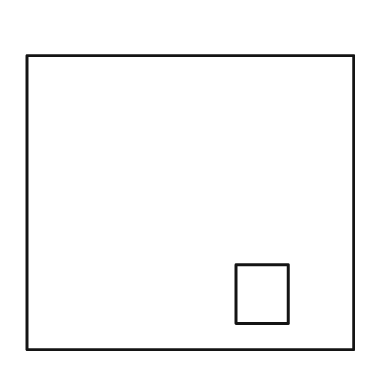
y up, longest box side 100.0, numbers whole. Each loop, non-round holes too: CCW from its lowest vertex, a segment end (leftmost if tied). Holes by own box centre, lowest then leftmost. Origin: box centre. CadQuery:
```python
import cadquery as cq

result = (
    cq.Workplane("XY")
    .moveTo(-50.0, -45.0)
    .lineTo(50.0, -45.0)
    .lineTo(50.0, 45.0)
    .lineTo(-50.0, 45.0)
    .close()
    .moveTo(14.0, -37.0)
    .lineTo(30.0, -37.0)
    .lineTo(30.0, -19.0)
    .lineTo(14.0, -19.0)
    .close()
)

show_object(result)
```